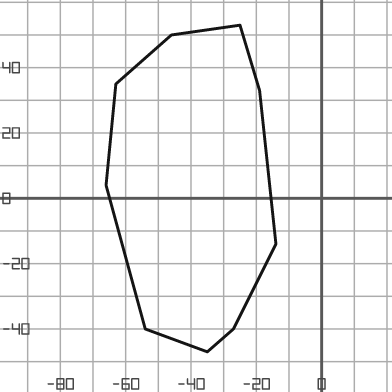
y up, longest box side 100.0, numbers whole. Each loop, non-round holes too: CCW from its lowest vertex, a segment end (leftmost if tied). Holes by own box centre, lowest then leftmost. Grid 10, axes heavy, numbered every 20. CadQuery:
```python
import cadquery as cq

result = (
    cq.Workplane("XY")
    .moveTo(-35.0, -47.0)
    .lineTo(-27.0, -40.0)
    .lineTo(-14.0, -14.0)
    .lineTo(-19.0, 33.0)
    .lineTo(-25.0, 53.0)
    .lineTo(-46.0, 50.0)
    .lineTo(-63.0, 35.0)
    .lineTo(-66.0, 4.0)
    .lineTo(-54.0, -40.0)
    .close()
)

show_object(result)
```